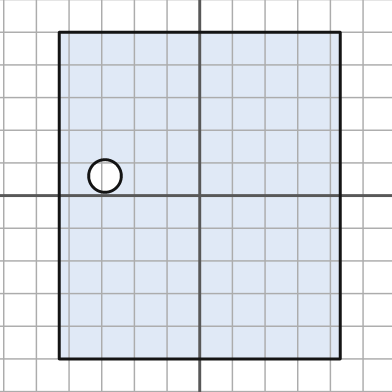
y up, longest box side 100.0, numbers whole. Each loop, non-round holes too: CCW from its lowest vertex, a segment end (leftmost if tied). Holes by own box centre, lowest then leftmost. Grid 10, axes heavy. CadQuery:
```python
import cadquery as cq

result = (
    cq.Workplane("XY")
    .moveTo(-43.0, -50.0)
    .lineTo(43.0, -50.0)
    .lineTo(43.0, 50.0)
    .lineTo(-43.0, 50.0)
    .close()
    .moveTo(-29.0, 6.0)
    .circle(5.0)
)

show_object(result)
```